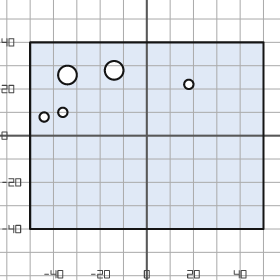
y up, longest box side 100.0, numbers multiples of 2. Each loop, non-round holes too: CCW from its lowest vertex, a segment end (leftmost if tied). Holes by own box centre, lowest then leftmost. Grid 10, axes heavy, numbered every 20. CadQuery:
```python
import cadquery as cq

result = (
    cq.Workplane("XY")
    .moveTo(-50.0, -40.0)
    .lineTo(50.0, -40.0)
    .lineTo(50.0, 40.0)
    .lineTo(-50.0, 40.0)
    .close()
    .moveTo(-44.0, 8.0)
    .circle(2.0)
    .moveTo(-36.0, 10.0)
    .circle(2.0)
    .moveTo(18.0, 22.0)
    .circle(2.0)
    .moveTo(-34.0, 26.0)
    .circle(4.0)
    .moveTo(-14.0, 28.0)
    .circle(4.0)
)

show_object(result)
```